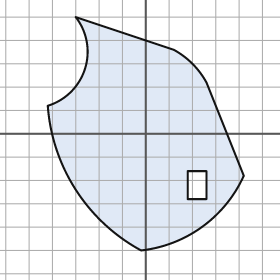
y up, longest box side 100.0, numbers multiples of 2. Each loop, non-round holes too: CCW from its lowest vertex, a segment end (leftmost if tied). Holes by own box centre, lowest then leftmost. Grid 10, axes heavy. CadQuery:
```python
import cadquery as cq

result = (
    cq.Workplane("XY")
    .moveTo(-2.0, -50.0)
    .threePointArc((24.0, -40.0), (42.0, -18.0))
    .lineTo(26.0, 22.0)
    .threePointArc((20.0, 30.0), (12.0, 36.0))
    .lineTo(-30.0, 50.0)
    .threePointArc((-26.0, 28.0), (-42.0, 12.0))
    .threePointArc((-30.0, -24.0), (-2.0, -50.0))
    .close()
    .moveTo(18.0, -28.0)
    .lineTo(26.0, -28.0)
    .lineTo(26.0, -16.0)
    .lineTo(18.0, -16.0)
    .close()
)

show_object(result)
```